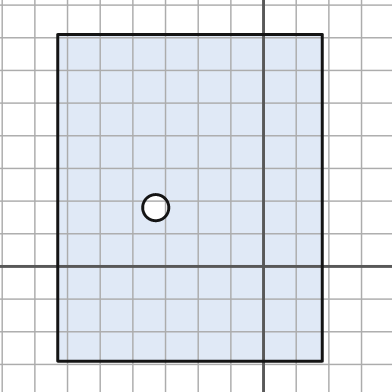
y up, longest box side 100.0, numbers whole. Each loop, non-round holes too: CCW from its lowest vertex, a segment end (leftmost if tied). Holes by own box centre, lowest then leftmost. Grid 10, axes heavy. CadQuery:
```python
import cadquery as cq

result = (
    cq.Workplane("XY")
    .moveTo(-63.0, -29.0)
    .lineTo(18.0, -29.0)
    .lineTo(18.0, 71.0)
    .lineTo(-63.0, 71.0)
    .close()
    .moveTo(-33.0, 18.0)
    .circle(4.0)
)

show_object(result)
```